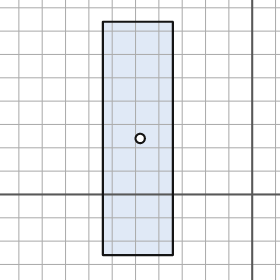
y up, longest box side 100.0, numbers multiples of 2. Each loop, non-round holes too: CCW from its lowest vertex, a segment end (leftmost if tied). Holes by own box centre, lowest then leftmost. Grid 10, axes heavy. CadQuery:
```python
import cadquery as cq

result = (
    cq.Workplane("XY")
    .moveTo(-64.0, -26.0)
    .lineTo(-34.0, -26.0)
    .lineTo(-34.0, 74.0)
    .lineTo(-64.0, 74.0)
    .close()
    .moveTo(-48.0, 24.0)
    .circle(2.0)
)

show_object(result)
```